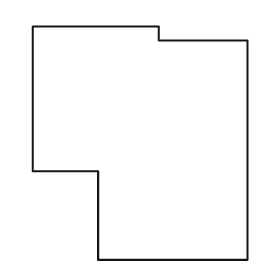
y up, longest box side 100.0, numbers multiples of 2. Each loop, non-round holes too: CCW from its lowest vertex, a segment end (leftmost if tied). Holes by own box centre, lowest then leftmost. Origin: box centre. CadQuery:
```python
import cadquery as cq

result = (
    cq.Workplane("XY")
    .moveTo(-18.0, -50.0)
    .lineTo(46.0, -50.0)
    .lineTo(46.0, 44.0)
    .lineTo(8.0, 44.0)
    .lineTo(8.0, 50.0)
    .lineTo(-46.0, 50.0)
    .lineTo(-46.0, -12.0)
    .lineTo(-18.0, -12.0)
    .close()
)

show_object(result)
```